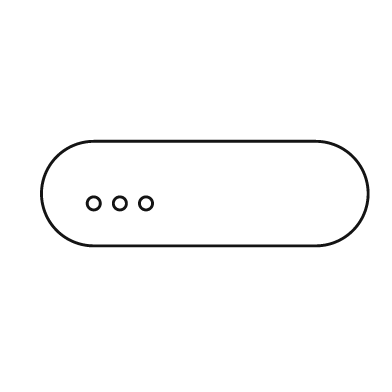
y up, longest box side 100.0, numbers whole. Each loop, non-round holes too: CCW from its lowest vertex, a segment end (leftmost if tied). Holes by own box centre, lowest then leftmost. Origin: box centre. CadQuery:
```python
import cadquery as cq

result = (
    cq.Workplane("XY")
    .moveTo(-34.0, -16.0)
    .lineTo(34.0, -16.0)
    .threePointArc((50.0, 0.0), (34.0, 16.0))
    .lineTo(-34.0, 16.0)
    .threePointArc((-50.0, 0.0), (-34.0, -16.0))
    .close()
    .moveTo(-34.0, -3.0)
    .circle(2.0)
    .moveTo(-26.0, -3.0)
    .circle(2.0)
    .moveTo(-18.0, -3.0)
    .circle(2.0)
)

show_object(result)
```